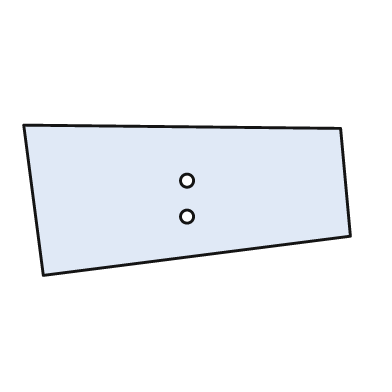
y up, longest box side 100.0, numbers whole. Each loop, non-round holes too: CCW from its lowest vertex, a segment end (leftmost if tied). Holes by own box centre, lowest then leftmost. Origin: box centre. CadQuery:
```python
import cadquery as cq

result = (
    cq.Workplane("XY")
    .moveTo(-44.0, -23.0)
    .lineTo(50.0, -11.0)
    .lineTo(47.0, 22.0)
    .lineTo(-50.0, 23.0)
    .close()
    .moveTo(0.0, -5.0)
    .circle(2.0)
    .moveTo(0.0, 6.0)
    .circle(2.0)
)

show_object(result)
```